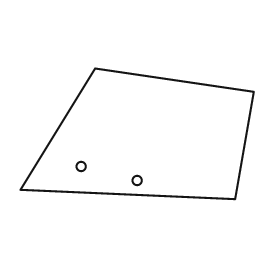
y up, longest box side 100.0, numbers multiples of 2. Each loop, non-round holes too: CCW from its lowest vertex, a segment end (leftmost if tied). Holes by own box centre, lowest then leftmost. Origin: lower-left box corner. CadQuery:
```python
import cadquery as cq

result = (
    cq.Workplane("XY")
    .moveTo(92.0, 0.0)
    .lineTo(100.0, 46.0)
    .lineTo(32.0, 56.0)
    .lineTo(0.0, 4.0)
    .close()
    .moveTo(50.0, 8.0)
    .circle(2.0)
    .moveTo(26.0, 14.0)
    .circle(2.0)
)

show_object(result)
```